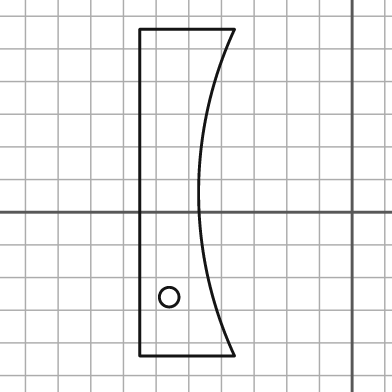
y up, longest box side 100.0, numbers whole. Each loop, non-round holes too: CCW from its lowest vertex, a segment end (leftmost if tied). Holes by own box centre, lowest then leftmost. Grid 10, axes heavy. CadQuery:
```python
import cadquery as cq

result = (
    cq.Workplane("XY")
    .moveTo(-65.0, -44.0)
    .lineTo(-36.0, -44.0)
    .threePointArc((-47.0, 6.0), (-36.0, 56.0))
    .lineTo(-65.0, 56.0)
    .close()
    .moveTo(-56.0, -26.0)
    .circle(3.0)
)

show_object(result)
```